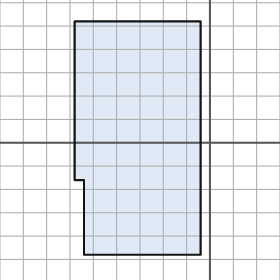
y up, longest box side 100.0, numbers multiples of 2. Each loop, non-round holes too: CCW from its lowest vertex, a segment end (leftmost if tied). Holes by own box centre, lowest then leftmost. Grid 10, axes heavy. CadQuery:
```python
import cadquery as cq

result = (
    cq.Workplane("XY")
    .moveTo(-54.0, -48.0)
    .lineTo(-4.0, -48.0)
    .lineTo(-4.0, 52.0)
    .lineTo(-58.0, 52.0)
    .lineTo(-58.0, -16.0)
    .lineTo(-54.0, -16.0)
    .close()
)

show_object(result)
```